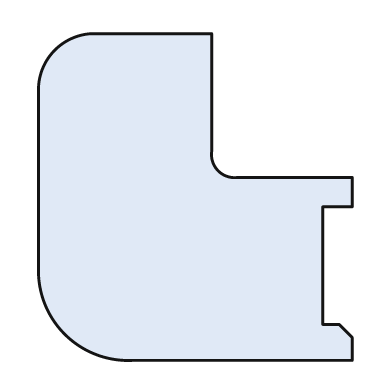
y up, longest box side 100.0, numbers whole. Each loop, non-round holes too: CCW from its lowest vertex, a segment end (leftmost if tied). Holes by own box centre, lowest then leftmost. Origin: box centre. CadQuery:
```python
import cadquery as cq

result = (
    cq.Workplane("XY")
    .moveTo(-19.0, -50.0)
    .lineTo(48.0, -50.0)
    .lineTo(48.0, -43.0)
    .lineTo(44.0, -39.0)
    .lineTo(39.0, -39.0)
    .lineTo(39.0, -3.0)
    .lineTo(48.0, -3.0)
    .lineTo(48.0, 6.0)
    .lineTo(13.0, 6.0)
    .threePointArc((7.0, 8.0), (5.0, 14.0))
    .lineTo(5.0, 50.0)
    .lineTo(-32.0, 50.0)
    .threePointArc((-43.0, 45.0), (-48.0, 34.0))
    .lineTo(-48.0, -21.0)
    .threePointArc((-40.0, -42.0), (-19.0, -50.0))
    .close()
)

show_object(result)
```